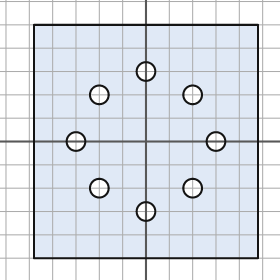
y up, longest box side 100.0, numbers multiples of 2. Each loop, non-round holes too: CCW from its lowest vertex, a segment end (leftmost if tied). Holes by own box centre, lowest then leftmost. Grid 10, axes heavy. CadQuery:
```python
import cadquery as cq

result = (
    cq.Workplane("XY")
    .moveTo(-48.0, -50.0)
    .lineTo(48.0, -50.0)
    .lineTo(48.0, 50.0)
    .lineTo(-48.0, 50.0)
    .close()
    .moveTo(0.0, -30.0)
    .circle(4.0)
    .moveTo(-20.0, -20.0)
    .circle(4.0)
    .moveTo(20.0, -20.0)
    .circle(4.0)
    .moveTo(-30.0, 0.0)
    .circle(4.0)
    .moveTo(30.0, 0.0)
    .circle(4.0)
    .moveTo(-20.0, 20.0)
    .circle(4.0)
    .moveTo(20.0, 20.0)
    .circle(4.0)
    .moveTo(0.0, 30.0)
    .circle(4.0)
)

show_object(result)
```